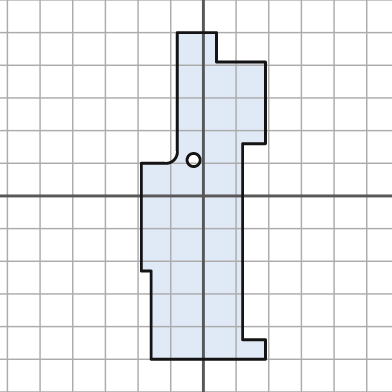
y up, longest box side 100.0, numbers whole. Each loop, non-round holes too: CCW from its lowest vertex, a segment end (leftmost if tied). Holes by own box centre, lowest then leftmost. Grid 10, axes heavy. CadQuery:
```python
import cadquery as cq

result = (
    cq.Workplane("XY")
    .moveTo(-16.0, -50.0)
    .lineTo(19.0, -50.0)
    .lineTo(19.0, -44.0)
    .lineTo(12.0, -44.0)
    .lineTo(12.0, 16.0)
    .lineTo(19.0, 16.0)
    .lineTo(19.0, 41.0)
    .lineTo(4.0, 41.0)
    .lineTo(4.0, 50.0)
    .lineTo(-8.0, 50.0)
    .lineTo(-8.0, 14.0)
    .threePointArc((-9.0, 11.0), (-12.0, 10.0))
    .lineTo(-19.0, 10.0)
    .lineTo(-19.0, -23.0)
    .lineTo(-16.0, -23.0)
    .close()
    .moveTo(-3.0, 11.0)
    .circle(2.0)
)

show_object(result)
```